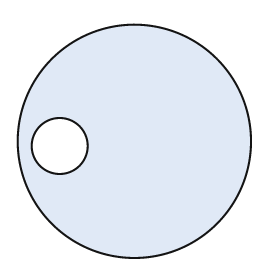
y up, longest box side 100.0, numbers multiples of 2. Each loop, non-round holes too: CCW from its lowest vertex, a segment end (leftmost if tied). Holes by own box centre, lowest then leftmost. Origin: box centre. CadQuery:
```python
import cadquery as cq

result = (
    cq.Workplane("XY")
    .moveTo(0.0, 0.0)
    .circle(50.0)
    .moveTo(-32.0, -2.0)
    .circle(12.0)
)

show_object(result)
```